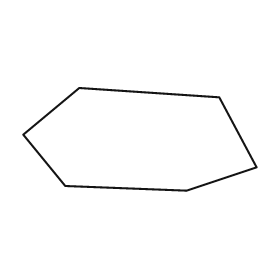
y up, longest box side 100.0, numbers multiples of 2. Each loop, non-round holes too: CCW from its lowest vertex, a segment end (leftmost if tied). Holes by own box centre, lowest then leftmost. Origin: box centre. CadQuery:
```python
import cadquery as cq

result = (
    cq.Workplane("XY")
    .moveTo(20.0, -22.0)
    .lineTo(50.0, -12.0)
    .lineTo(34.0, 18.0)
    .lineTo(-26.0, 22.0)
    .lineTo(-50.0, 2.0)
    .lineTo(-32.0, -20.0)
    .close()
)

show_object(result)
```